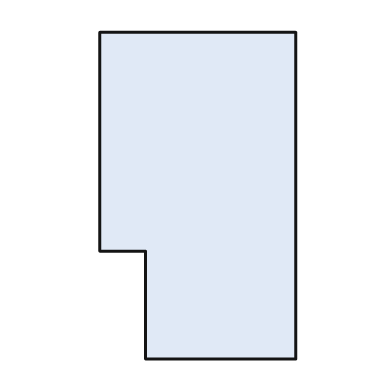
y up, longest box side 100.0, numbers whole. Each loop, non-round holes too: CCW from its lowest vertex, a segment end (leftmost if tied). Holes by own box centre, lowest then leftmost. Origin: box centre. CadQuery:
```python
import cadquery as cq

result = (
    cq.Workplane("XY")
    .moveTo(-16.0, -50.0)
    .lineTo(30.0, -50.0)
    .lineTo(30.0, 50.0)
    .lineTo(-30.0, 50.0)
    .lineTo(-30.0, -17.0)
    .lineTo(-16.0, -17.0)
    .close()
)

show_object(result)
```